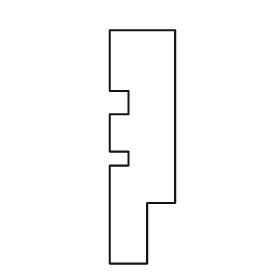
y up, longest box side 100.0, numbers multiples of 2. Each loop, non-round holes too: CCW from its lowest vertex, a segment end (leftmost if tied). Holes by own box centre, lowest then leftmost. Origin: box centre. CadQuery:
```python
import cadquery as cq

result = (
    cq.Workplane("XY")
    .moveTo(-14.0, -50.0)
    .lineTo(2.0, -50.0)
    .lineTo(2.0, -24.0)
    .lineTo(14.0, -24.0)
    .lineTo(14.0, 50.0)
    .lineTo(-14.0, 50.0)
    .lineTo(-14.0, 24.0)
    .lineTo(-6.0, 24.0)
    .lineTo(-6.0, 14.0)
    .lineTo(-14.0, 14.0)
    .lineTo(-14.0, -2.0)
    .lineTo(-6.0, -2.0)
    .lineTo(-6.0, -8.0)
    .lineTo(-14.0, -8.0)
    .close()
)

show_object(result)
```